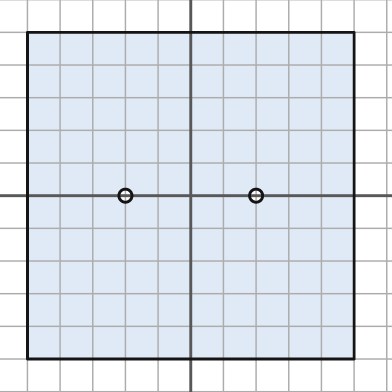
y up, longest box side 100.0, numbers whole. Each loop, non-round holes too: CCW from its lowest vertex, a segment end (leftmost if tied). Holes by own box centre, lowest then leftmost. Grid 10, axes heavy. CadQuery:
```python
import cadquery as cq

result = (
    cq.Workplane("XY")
    .moveTo(-50.0, -50.0)
    .lineTo(50.0, -50.0)
    .lineTo(50.0, 50.0)
    .lineTo(-50.0, 50.0)
    .close()
    .moveTo(-20.0, 0.0)
    .circle(2.0)
    .moveTo(20.0, 0.0)
    .circle(2.0)
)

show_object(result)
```